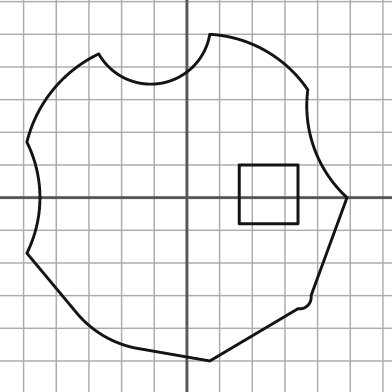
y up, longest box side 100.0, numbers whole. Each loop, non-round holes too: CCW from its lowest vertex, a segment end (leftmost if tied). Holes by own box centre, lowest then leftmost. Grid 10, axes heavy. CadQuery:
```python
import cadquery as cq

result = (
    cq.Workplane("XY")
    .moveTo(7.0, -50.0)
    .lineTo(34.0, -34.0)
    .threePointArc((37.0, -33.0), (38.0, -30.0))
    .lineTo(49.0, 0.0)
    .threePointArc((39.0, 15.0), (37.0, 33.0))
    .threePointArc((24.0, 45.0), (7.0, 50.0))
    .threePointArc((-8.0, 35.0), (-27.0, 44.0))
    .threePointArc((-41.0, 33.0), (-49.0, 17.0))
    .threePointArc((-45.0, 0.0), (-49.0, -17.0))
    .lineTo(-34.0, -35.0)
    .threePointArc((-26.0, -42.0), (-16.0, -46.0))
    .close()
    .moveTo(16.0, -8.0)
    .lineTo(34.0, -8.0)
    .lineTo(34.0, 10.0)
    .lineTo(16.0, 10.0)
    .close()
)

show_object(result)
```